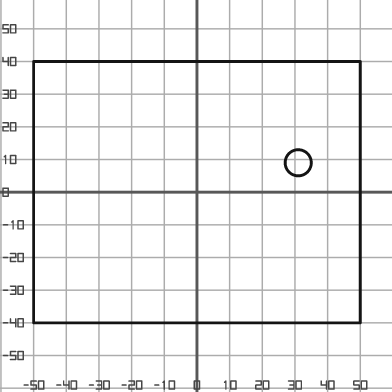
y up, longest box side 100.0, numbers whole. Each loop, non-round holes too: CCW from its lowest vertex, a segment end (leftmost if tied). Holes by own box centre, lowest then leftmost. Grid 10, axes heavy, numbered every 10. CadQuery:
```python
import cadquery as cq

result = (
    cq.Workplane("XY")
    .moveTo(-50.0, -40.0)
    .lineTo(50.0, -40.0)
    .lineTo(50.0, 40.0)
    .lineTo(-50.0, 40.0)
    .close()
    .moveTo(31.0, 9.0)
    .circle(4.0)
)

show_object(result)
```